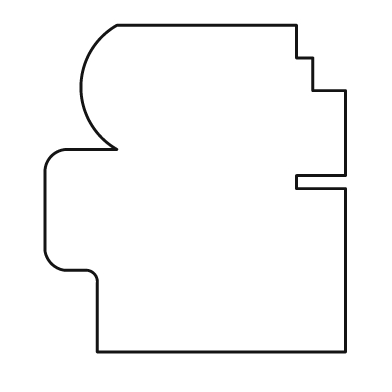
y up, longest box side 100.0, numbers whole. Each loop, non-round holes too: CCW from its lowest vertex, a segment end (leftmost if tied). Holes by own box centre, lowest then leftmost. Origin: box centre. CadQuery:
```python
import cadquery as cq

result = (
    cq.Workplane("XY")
    .moveTo(-30.0, -50.0)
    .lineTo(46.0, -50.0)
    .lineTo(46.0, 0.0)
    .lineTo(31.0, 0.0)
    .lineTo(31.0, 4.0)
    .lineTo(46.0, 4.0)
    .lineTo(46.0, 30.0)
    .lineTo(36.0, 30.0)
    .lineTo(36.0, 40.0)
    .lineTo(31.0, 40.0)
    .lineTo(31.0, 50.0)
    .lineTo(-24.0, 50.0)
    .threePointArc((-35.0, 31.0), (-24.0, 12.0))
    .lineTo(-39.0, 12.0)
    .threePointArc((-44.0, 10.0), (-46.0, 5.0))
    .lineTo(-46.0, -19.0)
    .threePointArc((-44.0, -23.0), (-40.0, -25.0))
    .lineTo(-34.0, -25.0)
    .threePointArc((-31.0, -26.0), (-30.0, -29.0))
    .close()
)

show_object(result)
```